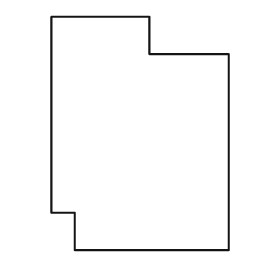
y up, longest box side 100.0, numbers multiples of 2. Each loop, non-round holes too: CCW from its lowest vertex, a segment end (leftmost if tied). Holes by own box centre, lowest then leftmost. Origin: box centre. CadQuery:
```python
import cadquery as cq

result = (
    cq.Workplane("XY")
    .moveTo(-28.0, -50.0)
    .lineTo(38.0, -50.0)
    .lineTo(38.0, 34.0)
    .lineTo(4.0, 34.0)
    .lineTo(4.0, 50.0)
    .lineTo(-38.0, 50.0)
    .lineTo(-38.0, -34.0)
    .lineTo(-28.0, -34.0)
    .close()
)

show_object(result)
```